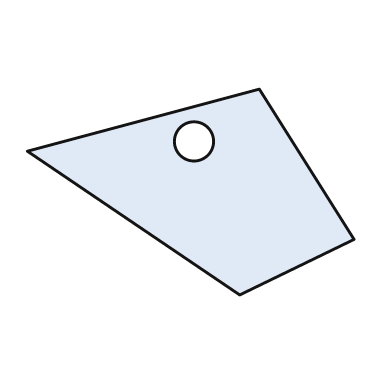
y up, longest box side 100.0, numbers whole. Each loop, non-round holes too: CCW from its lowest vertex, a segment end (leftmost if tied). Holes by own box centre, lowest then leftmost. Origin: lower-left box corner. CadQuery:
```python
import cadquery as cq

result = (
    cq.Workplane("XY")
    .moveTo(65.0, 0.0)
    .lineTo(100.0, 17.0)
    .lineTo(71.0, 63.0)
    .lineTo(0.0, 44.0)
    .close()
    .moveTo(51.0, 47.0)
    .circle(6.0)
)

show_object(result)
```